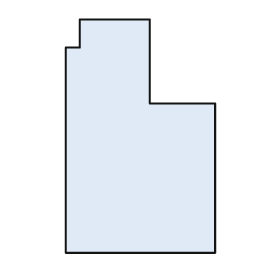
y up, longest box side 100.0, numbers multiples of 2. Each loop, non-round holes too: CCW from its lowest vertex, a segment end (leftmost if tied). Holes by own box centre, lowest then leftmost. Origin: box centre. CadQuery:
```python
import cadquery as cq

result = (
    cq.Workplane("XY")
    .moveTo(-32.0, -50.0)
    .lineTo(32.0, -50.0)
    .lineTo(32.0, 14.0)
    .lineTo(4.0, 14.0)
    .lineTo(4.0, 50.0)
    .lineTo(-26.0, 50.0)
    .lineTo(-26.0, 38.0)
    .lineTo(-32.0, 38.0)
    .close()
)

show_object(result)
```